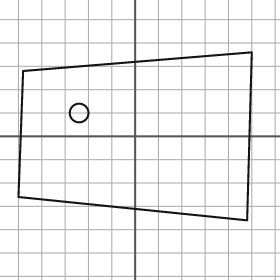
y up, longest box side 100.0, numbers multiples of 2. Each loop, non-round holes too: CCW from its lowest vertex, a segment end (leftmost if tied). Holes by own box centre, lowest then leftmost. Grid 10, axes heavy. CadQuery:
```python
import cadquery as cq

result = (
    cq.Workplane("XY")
    .moveTo(48.0, -36.0)
    .lineTo(50.0, 36.0)
    .lineTo(-48.0, 28.0)
    .lineTo(-50.0, -26.0)
    .close()
    .moveTo(-24.0, 10.0)
    .circle(4.0)
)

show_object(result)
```